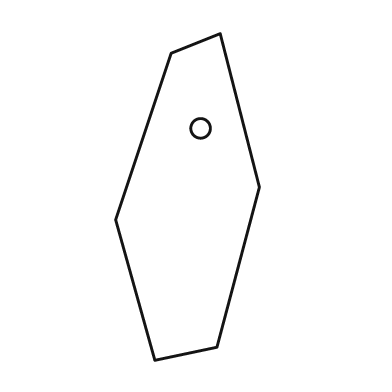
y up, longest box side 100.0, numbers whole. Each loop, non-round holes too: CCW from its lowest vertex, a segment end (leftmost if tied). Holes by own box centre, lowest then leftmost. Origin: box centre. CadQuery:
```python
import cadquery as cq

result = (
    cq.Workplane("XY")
    .moveTo(-10.0, -50.0)
    .lineTo(9.0, -46.0)
    .lineTo(22.0, 3.0)
    .lineTo(10.0, 50.0)
    .lineTo(-5.0, 44.0)
    .lineTo(-22.0, -7.0)
    .close()
    .moveTo(4.0, 21.0)
    .circle(3.0)
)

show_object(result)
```